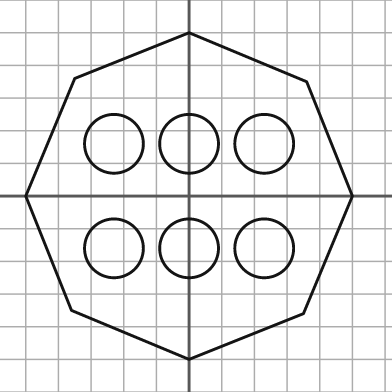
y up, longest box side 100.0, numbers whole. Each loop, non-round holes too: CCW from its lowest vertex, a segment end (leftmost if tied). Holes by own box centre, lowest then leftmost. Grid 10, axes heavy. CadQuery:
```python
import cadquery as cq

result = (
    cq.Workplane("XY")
    .moveTo(0.0, -50.0)
    .lineTo(35.0, -36.0)
    .lineTo(50.0, 0.0)
    .lineTo(36.0, 35.0)
    .lineTo(0.0, 50.0)
    .lineTo(-35.0, 36.0)
    .lineTo(-50.0, 0.0)
    .lineTo(-36.0, -35.0)
    .close()
    .moveTo(-23.0, -16.0)
    .circle(9.0)
    .moveTo(0.0, -16.0)
    .circle(9.0)
    .moveTo(23.0, -16.0)
    .circle(9.0)
    .moveTo(-23.0, 16.0)
    .circle(9.0)
    .moveTo(0.0, 16.0)
    .circle(9.0)
    .moveTo(23.0, 16.0)
    .circle(9.0)
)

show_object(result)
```